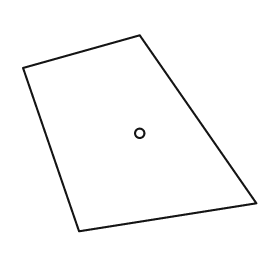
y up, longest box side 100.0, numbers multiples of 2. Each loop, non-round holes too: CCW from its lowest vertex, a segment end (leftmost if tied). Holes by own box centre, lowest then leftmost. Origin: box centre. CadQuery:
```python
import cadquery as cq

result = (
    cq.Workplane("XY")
    .moveTo(-26.0, -42.0)
    .lineTo(50.0, -30.0)
    .lineTo(0.0, 42.0)
    .lineTo(-50.0, 28.0)
    .close()
    .moveTo(0.0, 0.0)
    .circle(2.0)
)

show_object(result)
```